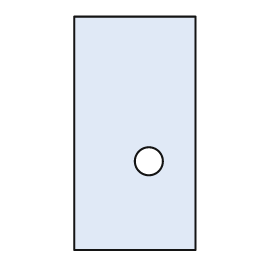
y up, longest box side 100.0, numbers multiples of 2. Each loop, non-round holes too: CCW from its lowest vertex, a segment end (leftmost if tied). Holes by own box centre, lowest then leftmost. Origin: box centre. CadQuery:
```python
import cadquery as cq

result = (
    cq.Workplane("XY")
    .moveTo(-26.0, -50.0)
    .lineTo(26.0, -50.0)
    .lineTo(26.0, 50.0)
    .lineTo(-26.0, 50.0)
    .close()
    .moveTo(6.0, -12.0)
    .circle(6.0)
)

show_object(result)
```